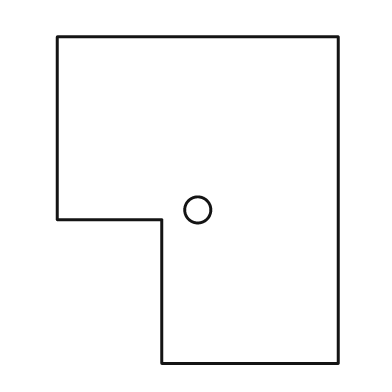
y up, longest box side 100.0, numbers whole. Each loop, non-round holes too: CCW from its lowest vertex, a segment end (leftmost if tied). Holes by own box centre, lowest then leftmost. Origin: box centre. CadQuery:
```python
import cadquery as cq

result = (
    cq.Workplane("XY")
    .moveTo(-11.0, -50.0)
    .lineTo(43.0, -50.0)
    .lineTo(43.0, 50.0)
    .lineTo(-43.0, 50.0)
    .lineTo(-43.0, -6.0)
    .lineTo(-11.0, -6.0)
    .close()
    .moveTo(0.0, -3.0)
    .circle(4.0)
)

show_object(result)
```